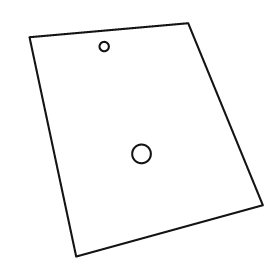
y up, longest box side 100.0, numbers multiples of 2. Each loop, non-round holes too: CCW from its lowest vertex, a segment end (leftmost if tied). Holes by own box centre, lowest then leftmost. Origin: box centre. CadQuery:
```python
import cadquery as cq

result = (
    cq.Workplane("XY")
    .moveTo(-30.0, -50.0)
    .lineTo(50.0, -28.0)
    .lineTo(18.0, 50.0)
    .lineTo(-50.0, 44.0)
    .close()
    .moveTo(-2.0, -6.0)
    .circle(4.0)
    .moveTo(-18.0, 40.0)
    .circle(2.0)
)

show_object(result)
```